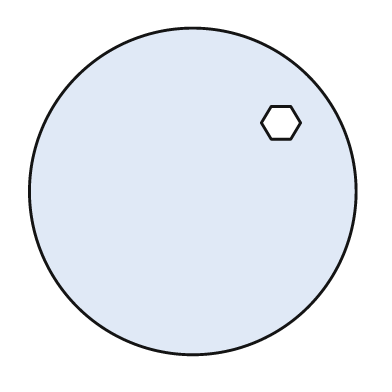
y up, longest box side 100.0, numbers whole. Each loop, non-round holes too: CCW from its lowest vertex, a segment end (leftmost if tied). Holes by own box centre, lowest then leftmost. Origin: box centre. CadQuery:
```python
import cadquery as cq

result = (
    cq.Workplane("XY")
    .moveTo(0.0, 0.0)
    .circle(50.0)
    .moveTo(24.0, 16.0)
    .lineTo(30.0, 16.0)
    .lineTo(33.0, 21.0)
    .lineTo(30.0, 26.0)
    .lineTo(24.0, 26.0)
    .lineTo(21.0, 21.0)
    .close()
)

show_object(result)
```